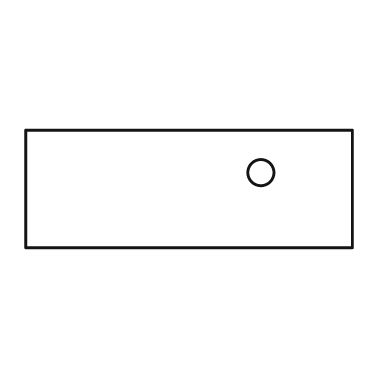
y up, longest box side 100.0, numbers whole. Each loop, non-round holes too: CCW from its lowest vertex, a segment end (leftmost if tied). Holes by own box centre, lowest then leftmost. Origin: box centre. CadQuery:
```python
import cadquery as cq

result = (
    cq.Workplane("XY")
    .moveTo(-50.0, -18.0)
    .lineTo(50.0, -18.0)
    .lineTo(50.0, 18.0)
    .lineTo(-50.0, 18.0)
    .close()
    .moveTo(22.0, 5.0)
    .circle(4.0)
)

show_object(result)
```